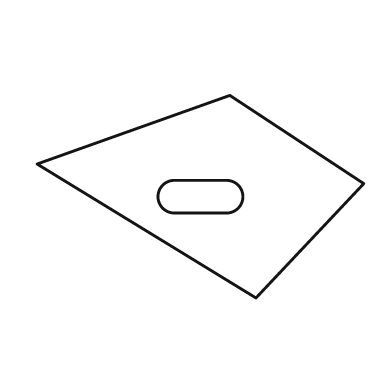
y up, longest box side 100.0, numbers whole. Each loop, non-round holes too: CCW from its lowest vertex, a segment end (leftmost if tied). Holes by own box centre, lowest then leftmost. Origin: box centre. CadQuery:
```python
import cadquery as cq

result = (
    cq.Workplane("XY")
    .moveTo(17.0, -31.0)
    .lineTo(50.0, 4.0)
    .lineTo(9.0, 31.0)
    .lineTo(-50.0, 10.0)
    .close()
    .moveTo(-8.0, -5.0)
    .lineTo(8.0, -5.0)
    .threePointArc((13.0, 0.0), (8.0, 5.0))
    .lineTo(-8.0, 5.0)
    .threePointArc((-13.0, 0.0), (-8.0, -5.0))
    .close()
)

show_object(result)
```